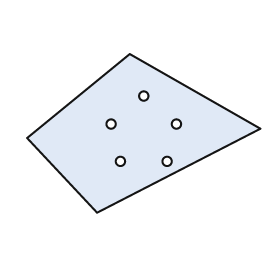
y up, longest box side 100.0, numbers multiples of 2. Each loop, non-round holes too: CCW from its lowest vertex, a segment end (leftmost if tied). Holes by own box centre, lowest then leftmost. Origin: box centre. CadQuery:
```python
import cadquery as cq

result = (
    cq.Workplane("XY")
    .moveTo(-20.0, -34.0)
    .lineTo(50.0, 2.0)
    .lineTo(-6.0, 34.0)
    .lineTo(-50.0, -2.0)
    .close()
    .moveTo(-10.0, -12.0)
    .circle(2.0)
    .moveTo(10.0, -12.0)
    .circle(2.0)
    .moveTo(-14.0, 4.0)
    .circle(2.0)
    .moveTo(14.0, 4.0)
    .circle(2.0)
    .moveTo(0.0, 16.0)
    .circle(2.0)
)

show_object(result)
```